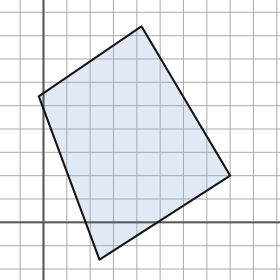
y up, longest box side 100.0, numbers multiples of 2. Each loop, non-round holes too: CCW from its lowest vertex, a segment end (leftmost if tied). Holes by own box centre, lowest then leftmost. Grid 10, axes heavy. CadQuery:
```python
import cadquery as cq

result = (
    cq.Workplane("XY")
    .moveTo(24.0, -16.0)
    .lineTo(80.0, 20.0)
    .lineTo(42.0, 84.0)
    .lineTo(-2.0, 54.0)
    .close()
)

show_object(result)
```